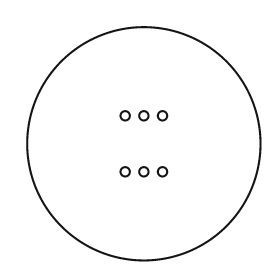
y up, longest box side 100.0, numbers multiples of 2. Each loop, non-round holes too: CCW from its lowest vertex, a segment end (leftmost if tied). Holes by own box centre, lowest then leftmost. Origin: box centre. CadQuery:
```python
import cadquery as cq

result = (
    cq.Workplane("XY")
    .moveTo(0.0, 0.0)
    .circle(50.0)
    .moveTo(-8.0, -12.0)
    .circle(2.0)
    .moveTo(0.0, -12.0)
    .circle(2.0)
    .moveTo(8.0, -12.0)
    .circle(2.0)
    .moveTo(-8.0, 12.0)
    .circle(2.0)
    .moveTo(0.0, 12.0)
    .circle(2.0)
    .moveTo(8.0, 12.0)
    .circle(2.0)
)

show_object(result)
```